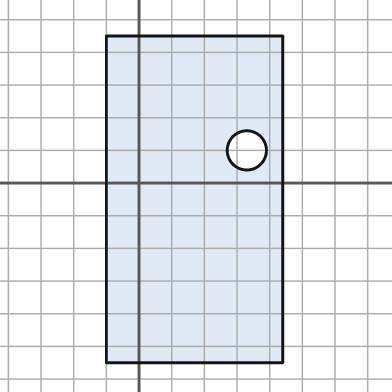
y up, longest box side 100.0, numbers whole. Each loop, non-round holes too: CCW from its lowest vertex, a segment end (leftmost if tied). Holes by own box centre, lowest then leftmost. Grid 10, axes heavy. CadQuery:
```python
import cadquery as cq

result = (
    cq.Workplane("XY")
    .moveTo(-10.0, -55.0)
    .lineTo(44.0, -55.0)
    .lineTo(44.0, 45.0)
    .lineTo(-10.0, 45.0)
    .close()
    .moveTo(33.0, 10.0)
    .circle(6.0)
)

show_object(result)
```